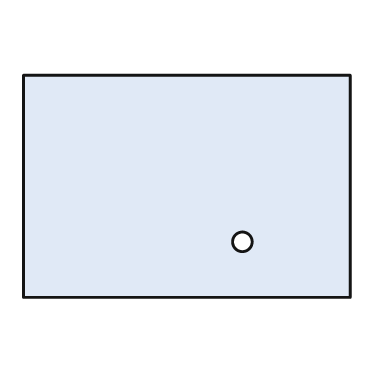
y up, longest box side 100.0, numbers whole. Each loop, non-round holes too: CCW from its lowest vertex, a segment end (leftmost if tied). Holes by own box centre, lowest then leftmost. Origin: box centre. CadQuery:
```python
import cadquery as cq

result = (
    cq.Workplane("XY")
    .moveTo(-50.0, -34.0)
    .lineTo(50.0, -34.0)
    .lineTo(50.0, 34.0)
    .lineTo(-50.0, 34.0)
    .close()
    .moveTo(17.0, -17.0)
    .circle(3.0)
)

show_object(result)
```